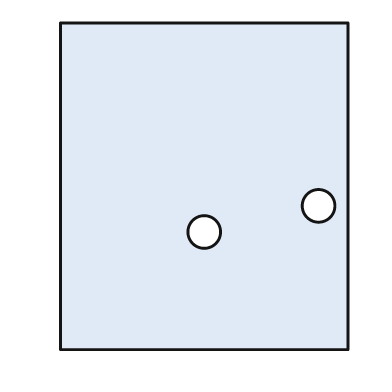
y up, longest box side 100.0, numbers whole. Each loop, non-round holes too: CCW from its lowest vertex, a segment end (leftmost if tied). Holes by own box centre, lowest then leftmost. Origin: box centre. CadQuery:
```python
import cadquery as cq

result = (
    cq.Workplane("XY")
    .moveTo(-44.0, -50.0)
    .lineTo(44.0, -50.0)
    .lineTo(44.0, 50.0)
    .lineTo(-44.0, 50.0)
    .close()
    .moveTo(0.0, -14.0)
    .circle(5.0)
    .moveTo(35.0, -6.0)
    .circle(5.0)
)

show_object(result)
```